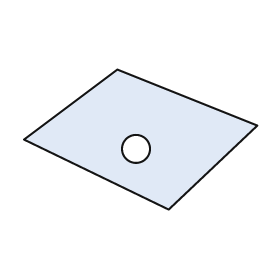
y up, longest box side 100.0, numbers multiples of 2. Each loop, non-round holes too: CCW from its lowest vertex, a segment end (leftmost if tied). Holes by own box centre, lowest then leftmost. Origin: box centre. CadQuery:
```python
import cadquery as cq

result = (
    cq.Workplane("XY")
    .moveTo(12.0, -30.0)
    .lineTo(50.0, 6.0)
    .lineTo(-10.0, 30.0)
    .lineTo(-50.0, 0.0)
    .close()
    .moveTo(-2.0, -4.0)
    .circle(6.0)
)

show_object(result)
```